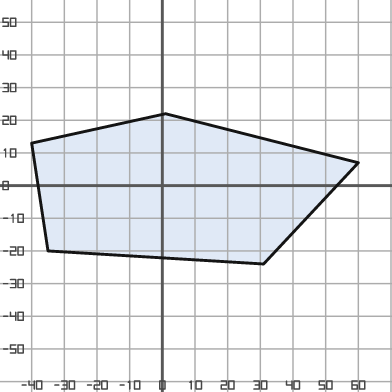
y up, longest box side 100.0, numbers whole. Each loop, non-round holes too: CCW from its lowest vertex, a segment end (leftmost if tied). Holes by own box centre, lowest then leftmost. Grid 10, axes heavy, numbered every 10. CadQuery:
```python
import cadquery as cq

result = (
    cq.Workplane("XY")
    .moveTo(31.0, -24.0)
    .lineTo(60.0, 7.0)
    .lineTo(1.0, 22.0)
    .lineTo(-40.0, 13.0)
    .lineTo(-35.0, -20.0)
    .close()
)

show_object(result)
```